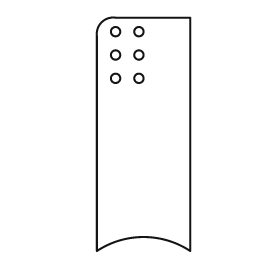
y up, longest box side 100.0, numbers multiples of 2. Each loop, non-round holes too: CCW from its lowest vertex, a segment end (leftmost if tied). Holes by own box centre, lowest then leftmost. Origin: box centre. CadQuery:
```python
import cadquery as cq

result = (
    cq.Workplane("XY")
    .moveTo(-20.0, -50.0)
    .threePointArc((0.0, -44.0), (20.0, -50.0))
    .lineTo(20.0, 50.0)
    .lineTo(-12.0, 50.0)
    .threePointArc((-18.0, 48.0), (-20.0, 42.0))
    .close()
    .moveTo(-12.0, 24.0)
    .circle(2.0)
    .moveTo(-2.0, 24.0)
    .circle(2.0)
    .moveTo(-12.0, 34.0)
    .circle(2.0)
    .moveTo(-2.0, 34.0)
    .circle(2.0)
    .moveTo(-12.0, 44.0)
    .circle(2.0)
    .moveTo(-2.0, 44.0)
    .circle(2.0)
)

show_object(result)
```